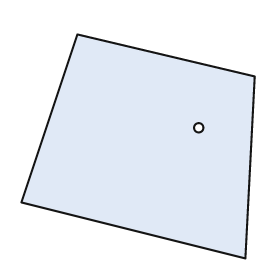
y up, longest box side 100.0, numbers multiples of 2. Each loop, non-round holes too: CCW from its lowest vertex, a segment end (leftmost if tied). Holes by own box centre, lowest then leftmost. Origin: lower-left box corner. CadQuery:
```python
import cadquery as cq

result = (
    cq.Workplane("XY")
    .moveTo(96.0, 0.0)
    .lineTo(100.0, 78.0)
    .lineTo(24.0, 96.0)
    .lineTo(0.0, 24.0)
    .close()
    .moveTo(76.0, 56.0)
    .circle(2.0)
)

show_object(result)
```